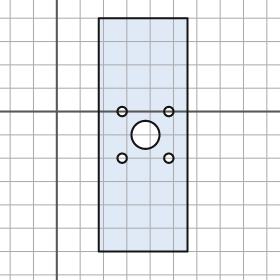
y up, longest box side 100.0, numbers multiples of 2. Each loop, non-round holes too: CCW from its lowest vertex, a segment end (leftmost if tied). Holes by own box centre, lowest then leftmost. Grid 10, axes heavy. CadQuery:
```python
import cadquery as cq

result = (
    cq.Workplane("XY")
    .moveTo(18.0, -60.0)
    .lineTo(56.0, -60.0)
    .lineTo(56.0, 40.0)
    .lineTo(18.0, 40.0)
    .close()
    .moveTo(28.0, -20.0)
    .circle(2.0)
    .moveTo(48.0, -20.0)
    .circle(2.0)
    .moveTo(38.0, -10.0)
    .circle(6.0)
    .moveTo(28.0, 0.0)
    .circle(2.0)
    .moveTo(48.0, 0.0)
    .circle(2.0)
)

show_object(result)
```